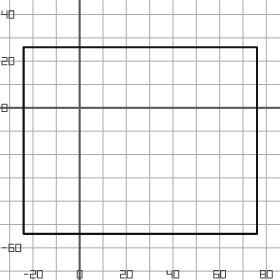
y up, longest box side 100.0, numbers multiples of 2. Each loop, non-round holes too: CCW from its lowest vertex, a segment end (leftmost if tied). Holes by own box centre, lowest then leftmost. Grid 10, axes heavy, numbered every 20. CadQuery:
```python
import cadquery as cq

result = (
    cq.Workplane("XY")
    .moveTo(-24.0, -54.0)
    .lineTo(76.0, -54.0)
    .lineTo(76.0, 26.0)
    .lineTo(-24.0, 26.0)
    .close()
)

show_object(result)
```